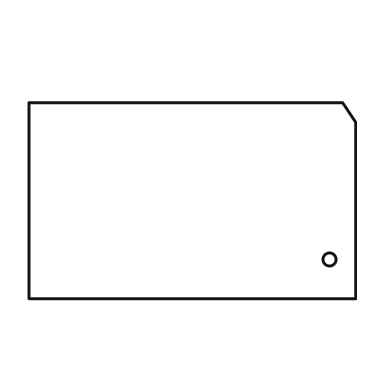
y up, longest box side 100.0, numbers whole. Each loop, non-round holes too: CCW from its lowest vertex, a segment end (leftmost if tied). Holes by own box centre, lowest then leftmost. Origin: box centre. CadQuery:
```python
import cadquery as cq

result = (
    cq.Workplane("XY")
    .moveTo(-50.0, -30.0)
    .lineTo(50.0, -30.0)
    .lineTo(50.0, 24.0)
    .lineTo(46.0, 30.0)
    .lineTo(-50.0, 30.0)
    .close()
    .moveTo(42.0, -18.0)
    .circle(2.0)
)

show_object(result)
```